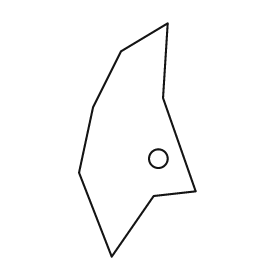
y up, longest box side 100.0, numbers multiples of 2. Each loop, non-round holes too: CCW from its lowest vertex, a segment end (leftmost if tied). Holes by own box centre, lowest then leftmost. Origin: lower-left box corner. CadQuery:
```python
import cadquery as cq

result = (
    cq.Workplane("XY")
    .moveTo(14.0, 0.0)
    .lineTo(32.0, 26.0)
    .lineTo(50.0, 28.0)
    .lineTo(36.0, 68.0)
    .lineTo(38.0, 100.0)
    .lineTo(18.0, 88.0)
    .lineTo(6.0, 64.0)
    .lineTo(0.0, 36.0)
    .close()
    .moveTo(34.0, 42.0)
    .circle(4.0)
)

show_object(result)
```